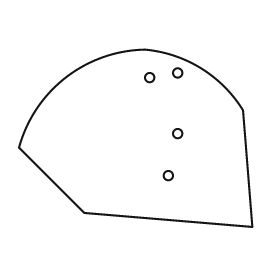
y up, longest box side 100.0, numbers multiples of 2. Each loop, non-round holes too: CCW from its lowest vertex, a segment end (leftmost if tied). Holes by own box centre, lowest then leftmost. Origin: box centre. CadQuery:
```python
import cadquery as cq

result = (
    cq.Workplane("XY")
    .moveTo(50.0, -38.0)
    .lineTo(46.0, 12.0)
    .threePointArc((28.0, 30.0), (4.0, 38.0))
    .threePointArc((-30.0, 26.0), (-50.0, -4.0))
    .lineTo(-22.0, -32.0)
    .close()
    .moveTo(14.0, -16.0)
    .circle(2.0)
    .moveTo(18.0, 2.0)
    .circle(2.0)
    .moveTo(6.0, 26.0)
    .circle(2.0)
    .moveTo(18.0, 28.0)
    .circle(2.0)
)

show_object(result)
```